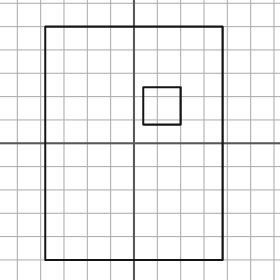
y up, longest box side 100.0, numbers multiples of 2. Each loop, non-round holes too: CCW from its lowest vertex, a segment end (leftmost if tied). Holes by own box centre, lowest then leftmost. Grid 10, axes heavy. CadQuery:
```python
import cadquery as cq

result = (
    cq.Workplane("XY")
    .moveTo(-38.0, -50.0)
    .lineTo(38.0, -50.0)
    .lineTo(38.0, 50.0)
    .lineTo(-38.0, 50.0)
    .close()
    .moveTo(4.0, 8.0)
    .lineTo(20.0, 8.0)
    .lineTo(20.0, 24.0)
    .lineTo(4.0, 24.0)
    .close()
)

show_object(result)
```